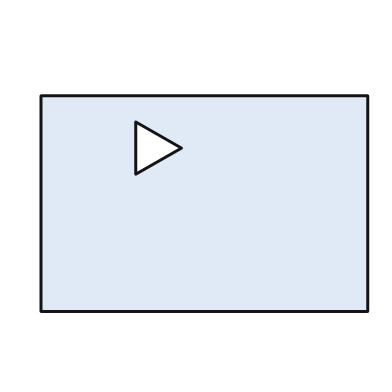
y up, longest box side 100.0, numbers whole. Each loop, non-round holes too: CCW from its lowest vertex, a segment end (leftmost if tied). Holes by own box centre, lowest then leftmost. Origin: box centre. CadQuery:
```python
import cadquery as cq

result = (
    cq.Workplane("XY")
    .moveTo(-50.0, -33.0)
    .lineTo(50.0, -33.0)
    .lineTo(50.0, 33.0)
    .lineTo(-50.0, 33.0)
    .close()
    .moveTo(-21.0, 9.0)
    .lineTo(-7.0, 17.0)
    .lineTo(-21.0, 25.0)
    .close()
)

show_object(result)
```